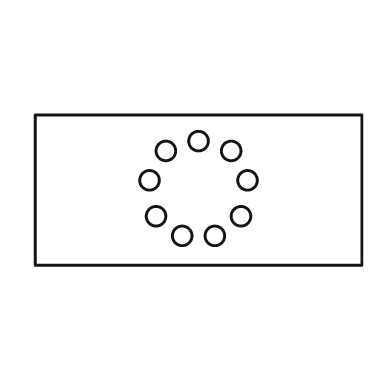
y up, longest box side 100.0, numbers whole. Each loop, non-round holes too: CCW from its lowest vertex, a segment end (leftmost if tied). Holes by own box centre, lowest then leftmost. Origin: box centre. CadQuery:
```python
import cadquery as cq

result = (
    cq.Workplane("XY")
    .moveTo(-50.0, -23.0)
    .lineTo(50.0, -23.0)
    .lineTo(50.0, 23.0)
    .lineTo(-50.0, 23.0)
    .close()
    .moveTo(-5.0, -14.0)
    .circle(3.0)
    .moveTo(5.0, -14.0)
    .circle(3.0)
    .moveTo(-13.0, -8.0)
    .circle(3.0)
    .moveTo(13.0, -8.0)
    .circle(3.0)
    .moveTo(-15.0, 3.0)
    .circle(3.0)
    .moveTo(15.0, 3.0)
    .circle(3.0)
    .moveTo(-10.0, 12.0)
    .circle(3.0)
    .moveTo(10.0, 12.0)
    .circle(3.0)
    .moveTo(0.0, 15.0)
    .circle(3.0)
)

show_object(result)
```